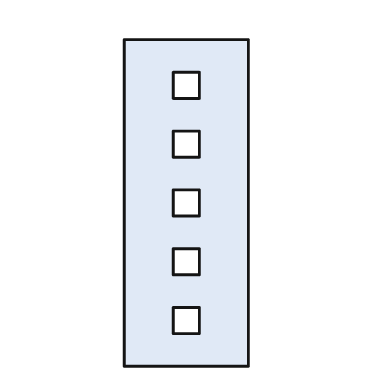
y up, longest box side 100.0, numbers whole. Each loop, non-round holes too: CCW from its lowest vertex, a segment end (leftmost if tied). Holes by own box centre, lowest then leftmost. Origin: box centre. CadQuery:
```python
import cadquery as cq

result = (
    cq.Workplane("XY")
    .moveTo(-19.0, -50.0)
    .lineTo(19.0, -50.0)
    .lineTo(19.0, 50.0)
    .lineTo(-19.0, 50.0)
    .close()
    .moveTo(-4.0, -40.0)
    .lineTo(4.0, -40.0)
    .lineTo(4.0, -32.0)
    .lineTo(-4.0, -32.0)
    .close()
    .moveTo(-4.0, -22.0)
    .lineTo(4.0, -22.0)
    .lineTo(4.0, -14.0)
    .lineTo(-4.0, -14.0)
    .close()
    .moveTo(-4.0, -4.0)
    .lineTo(4.0, -4.0)
    .lineTo(4.0, 4.0)
    .lineTo(-4.0, 4.0)
    .close()
    .moveTo(-4.0, 14.0)
    .lineTo(4.0, 14.0)
    .lineTo(4.0, 22.0)
    .lineTo(-4.0, 22.0)
    .close()
    .moveTo(-4.0, 32.0)
    .lineTo(4.0, 32.0)
    .lineTo(4.0, 40.0)
    .lineTo(-4.0, 40.0)
    .close()
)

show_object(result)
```